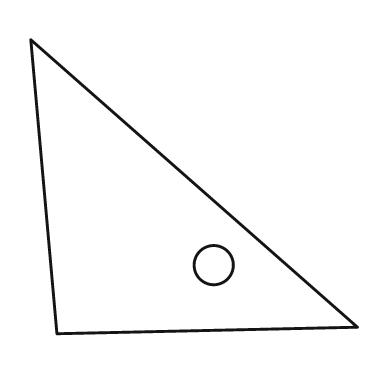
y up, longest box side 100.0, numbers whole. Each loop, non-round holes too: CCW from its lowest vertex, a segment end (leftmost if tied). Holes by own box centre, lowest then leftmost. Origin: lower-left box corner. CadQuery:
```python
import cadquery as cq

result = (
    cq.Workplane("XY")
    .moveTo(8.0, 0.0)
    .lineTo(100.0, 2.0)
    .lineTo(0.0, 90.0)
    .close()
    .moveTo(56.0, 21.0)
    .circle(6.0)
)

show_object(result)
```